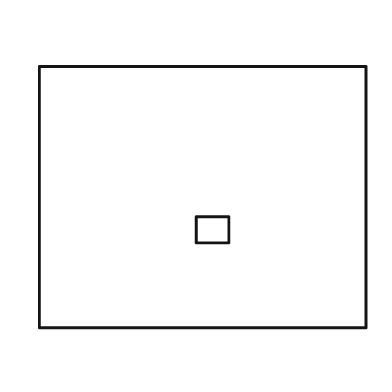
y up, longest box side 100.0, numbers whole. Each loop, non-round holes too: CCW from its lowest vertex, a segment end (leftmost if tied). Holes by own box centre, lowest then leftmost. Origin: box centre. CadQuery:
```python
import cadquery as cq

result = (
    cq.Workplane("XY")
    .moveTo(-50.0, -40.0)
    .lineTo(50.0, -40.0)
    .lineTo(50.0, 40.0)
    .lineTo(-50.0, 40.0)
    .close()
    .moveTo(-2.0, -14.0)
    .lineTo(8.0, -14.0)
    .lineTo(8.0, -6.0)
    .lineTo(-2.0, -6.0)
    .close()
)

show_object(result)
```